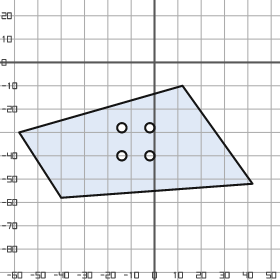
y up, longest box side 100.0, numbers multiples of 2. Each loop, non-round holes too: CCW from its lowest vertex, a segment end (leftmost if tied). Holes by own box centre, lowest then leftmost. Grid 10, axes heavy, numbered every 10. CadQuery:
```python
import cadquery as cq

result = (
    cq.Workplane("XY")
    .moveTo(-40.0, -58.0)
    .lineTo(42.0, -52.0)
    .lineTo(12.0, -10.0)
    .lineTo(-58.0, -30.0)
    .close()
    .moveTo(-14.0, -40.0)
    .circle(2.0)
    .moveTo(-2.0, -40.0)
    .circle(2.0)
    .moveTo(-14.0, -28.0)
    .circle(2.0)
    .moveTo(-2.0, -28.0)
    .circle(2.0)
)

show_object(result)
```